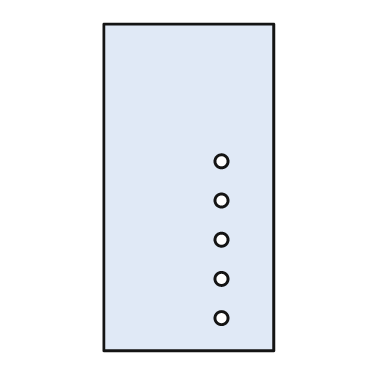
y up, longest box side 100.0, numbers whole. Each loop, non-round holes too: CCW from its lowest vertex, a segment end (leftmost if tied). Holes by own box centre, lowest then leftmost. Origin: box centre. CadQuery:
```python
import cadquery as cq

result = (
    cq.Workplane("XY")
    .moveTo(-26.0, -50.0)
    .lineTo(26.0, -50.0)
    .lineTo(26.0, 50.0)
    .lineTo(-26.0, 50.0)
    .close()
    .moveTo(10.0, -40.0)
    .circle(2.0)
    .moveTo(10.0, -28.0)
    .circle(2.0)
    .moveTo(10.0, -16.0)
    .circle(2.0)
    .moveTo(10.0, -4.0)
    .circle(2.0)
    .moveTo(10.0, 8.0)
    .circle(2.0)
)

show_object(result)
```